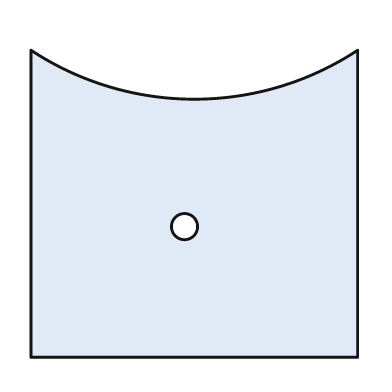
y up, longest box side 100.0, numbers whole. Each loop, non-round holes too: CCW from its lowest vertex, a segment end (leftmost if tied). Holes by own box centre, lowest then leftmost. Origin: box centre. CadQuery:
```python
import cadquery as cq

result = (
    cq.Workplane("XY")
    .moveTo(-50.0, -47.0)
    .lineTo(50.0, -47.0)
    .lineTo(50.0, 47.0)
    .threePointArc((0.0, 32.0), (-50.0, 47.0))
    .close()
    .moveTo(-3.0, -7.0)
    .circle(4.0)
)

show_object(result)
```